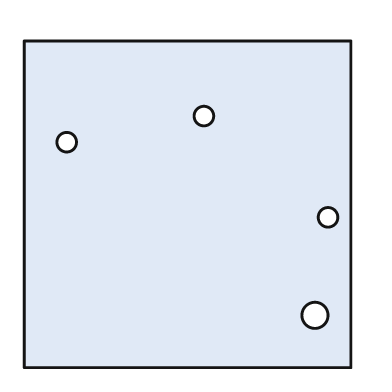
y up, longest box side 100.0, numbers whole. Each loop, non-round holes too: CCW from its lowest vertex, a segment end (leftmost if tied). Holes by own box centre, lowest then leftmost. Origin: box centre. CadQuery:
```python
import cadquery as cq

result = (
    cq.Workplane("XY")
    .moveTo(-50.0, -50.0)
    .lineTo(50.0, -50.0)
    .lineTo(50.0, 50.0)
    .lineTo(-50.0, 50.0)
    .close()
    .moveTo(39.0, -34.0)
    .circle(4.0)
    .moveTo(43.0, -4.0)
    .circle(3.0)
    .moveTo(-37.0, 19.0)
    .circle(3.0)
    .moveTo(5.0, 27.0)
    .circle(3.0)
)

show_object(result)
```